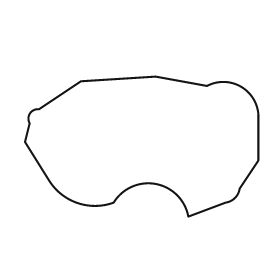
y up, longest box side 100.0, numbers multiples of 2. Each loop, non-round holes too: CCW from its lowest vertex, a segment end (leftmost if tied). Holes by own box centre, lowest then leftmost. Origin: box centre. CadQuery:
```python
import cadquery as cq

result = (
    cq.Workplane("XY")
    .moveTo(20.0, -30.0)
    .lineTo(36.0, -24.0)
    .threePointArc((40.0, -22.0), (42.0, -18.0))
    .lineTo(50.0, -6.0)
    .lineTo(50.0, 14.0)
    .threePointArc((42.0, 26.0), (28.0, 26.0))
    .lineTo(6.0, 30.0)
    .lineTo(-26.0, 28.0)
    .lineTo(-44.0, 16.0)
    .threePointArc((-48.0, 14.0), (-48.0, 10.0))
    .lineTo(-50.0, 2.0)
    .lineTo(-40.0, -14.0)
    .threePointArc((-28.0, -24.0), (-12.0, -24.0))
    .threePointArc((6.0, -16.0), (20.0, -30.0))
    .close()
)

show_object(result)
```